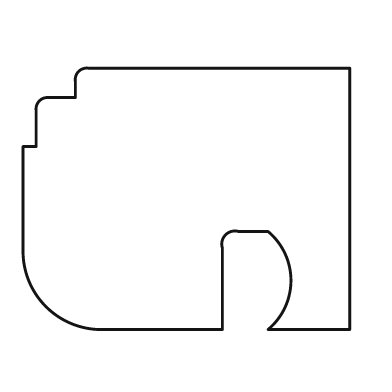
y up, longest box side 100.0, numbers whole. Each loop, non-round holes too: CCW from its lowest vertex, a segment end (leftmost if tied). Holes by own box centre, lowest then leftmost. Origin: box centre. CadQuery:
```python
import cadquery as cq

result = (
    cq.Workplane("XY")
    .moveTo(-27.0, -40.0)
    .lineTo(11.0, -40.0)
    .lineTo(11.0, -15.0)
    .threePointArc((12.0, -11.0), (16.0, -10.0))
    .lineTo(25.0, -10.0)
    .threePointArc((32.0, -25.0), (25.0, -40.0))
    .lineTo(50.0, -40.0)
    .lineTo(50.0, 40.0)
    .lineTo(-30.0, 40.0)
    .threePointArc((-33.0, 39.0), (-34.0, 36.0))
    .lineTo(-34.0, 31.0)
    .lineTo(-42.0, 31.0)
    .threePointArc((-45.0, 30.0), (-46.0, 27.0))
    .lineTo(-46.0, 16.0)
    .lineTo(-50.0, 16.0)
    .lineTo(-50.0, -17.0)
    .threePointArc((-43.0, -33.0), (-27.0, -40.0))
    .close()
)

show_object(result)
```